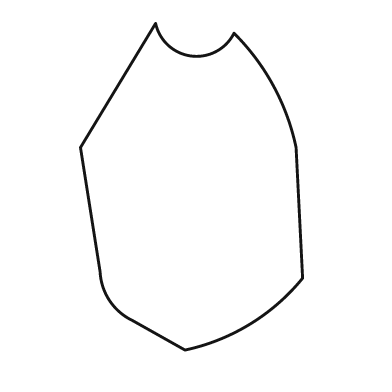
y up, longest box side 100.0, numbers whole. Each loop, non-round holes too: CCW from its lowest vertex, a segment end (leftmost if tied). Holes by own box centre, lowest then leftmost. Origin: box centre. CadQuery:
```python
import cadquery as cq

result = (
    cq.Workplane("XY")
    .moveTo(-2.0, -50.0)
    .threePointArc((18.0, -42.0), (34.0, -28.0))
    .lineTo(32.0, 12.0)
    .threePointArc((25.0, 31.0), (13.0, 47.0))
    .threePointArc((0.0, 40.0), (-11.0, 50.0))
    .lineTo(-34.0, 12.0)
    .lineTo(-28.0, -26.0)
    .threePointArc((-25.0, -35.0), (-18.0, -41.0))
    .close()
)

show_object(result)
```